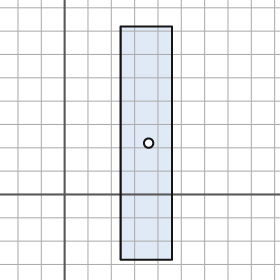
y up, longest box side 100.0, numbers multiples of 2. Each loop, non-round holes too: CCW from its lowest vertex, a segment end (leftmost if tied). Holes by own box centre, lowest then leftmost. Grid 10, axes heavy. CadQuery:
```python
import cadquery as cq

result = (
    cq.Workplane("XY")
    .moveTo(24.0, -28.0)
    .lineTo(46.0, -28.0)
    .lineTo(46.0, 72.0)
    .lineTo(24.0, 72.0)
    .close()
    .moveTo(36.0, 22.0)
    .circle(2.0)
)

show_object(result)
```